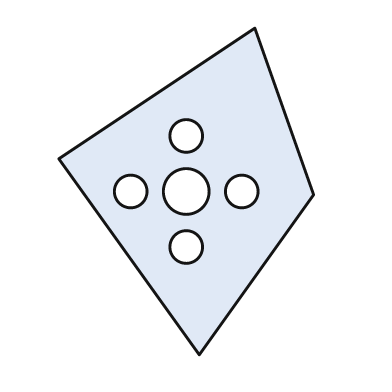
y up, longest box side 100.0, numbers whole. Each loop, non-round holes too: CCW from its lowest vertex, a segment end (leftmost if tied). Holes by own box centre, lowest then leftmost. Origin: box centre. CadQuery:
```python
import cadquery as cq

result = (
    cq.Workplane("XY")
    .moveTo(4.0, -50.0)
    .lineTo(39.0, -1.0)
    .lineTo(21.0, 50.0)
    .lineTo(-39.0, 10.0)
    .close()
    .moveTo(0.0, -17.0)
    .circle(5.0)
    .moveTo(-17.0, 0.0)
    .circle(5.0)
    .moveTo(0.0, 0.0)
    .circle(7.0)
    .moveTo(17.0, 0.0)
    .circle(5.0)
    .moveTo(0.0, 17.0)
    .circle(5.0)
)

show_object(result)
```